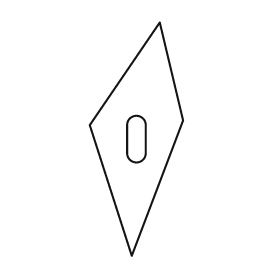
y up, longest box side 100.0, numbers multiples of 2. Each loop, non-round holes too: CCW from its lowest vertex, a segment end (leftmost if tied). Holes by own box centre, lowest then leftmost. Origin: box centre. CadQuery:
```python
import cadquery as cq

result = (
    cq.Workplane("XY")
    .moveTo(-2.0, -50.0)
    .lineTo(20.0, 8.0)
    .lineTo(10.0, 50.0)
    .lineTo(-20.0, 6.0)
    .close()
    .moveTo(-4.0, -6.0)
    .threePointArc((0.0, -10.0), (4.0, -6.0))
    .lineTo(4.0, 6.0)
    .threePointArc((0.0, 10.0), (-4.0, 6.0))
    .close()
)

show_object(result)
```